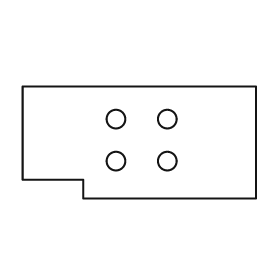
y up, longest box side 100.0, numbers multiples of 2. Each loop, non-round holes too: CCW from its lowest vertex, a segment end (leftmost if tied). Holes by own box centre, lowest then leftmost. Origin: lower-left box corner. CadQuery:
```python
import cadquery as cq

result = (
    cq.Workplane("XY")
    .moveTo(26.0, 0.0)
    .lineTo(100.0, 0.0)
    .lineTo(100.0, 48.0)
    .lineTo(0.0, 48.0)
    .lineTo(0.0, 8.0)
    .lineTo(26.0, 8.0)
    .close()
    .moveTo(40.0, 16.0)
    .circle(4.0)
    .moveTo(62.0, 16.0)
    .circle(4.0)
    .moveTo(40.0, 34.0)
    .circle(4.0)
    .moveTo(62.0, 34.0)
    .circle(4.0)
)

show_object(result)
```